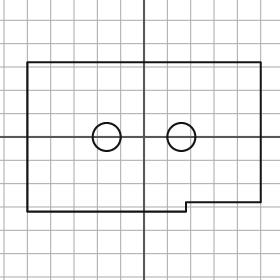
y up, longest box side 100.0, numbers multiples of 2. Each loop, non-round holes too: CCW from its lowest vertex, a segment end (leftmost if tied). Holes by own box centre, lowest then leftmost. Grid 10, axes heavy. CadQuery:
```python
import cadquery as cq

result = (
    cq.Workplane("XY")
    .moveTo(-50.0, -32.0)
    .lineTo(18.0, -32.0)
    .lineTo(18.0, -28.0)
    .lineTo(50.0, -28.0)
    .lineTo(50.0, 32.0)
    .lineTo(-50.0, 32.0)
    .close()
    .moveTo(-16.0, 0.0)
    .circle(6.0)
    .moveTo(16.0, 0.0)
    .circle(6.0)
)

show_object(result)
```